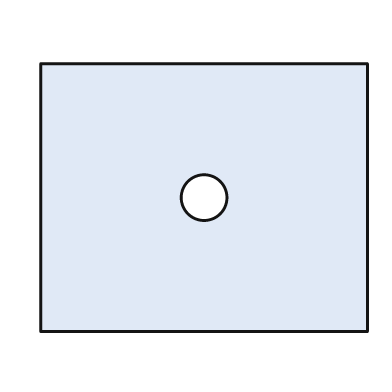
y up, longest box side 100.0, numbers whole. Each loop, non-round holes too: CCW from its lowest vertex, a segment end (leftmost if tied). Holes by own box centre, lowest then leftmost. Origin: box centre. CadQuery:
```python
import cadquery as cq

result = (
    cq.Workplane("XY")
    .moveTo(-50.0, -41.0)
    .lineTo(50.0, -41.0)
    .lineTo(50.0, 41.0)
    .lineTo(-50.0, 41.0)
    .close()
    .moveTo(0.0, 0.0)
    .circle(7.0)
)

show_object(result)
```